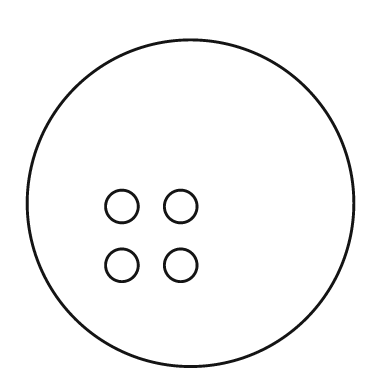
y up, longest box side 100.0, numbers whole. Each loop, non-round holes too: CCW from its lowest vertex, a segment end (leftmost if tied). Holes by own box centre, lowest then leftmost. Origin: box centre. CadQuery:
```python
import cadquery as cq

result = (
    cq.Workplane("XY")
    .moveTo(0.0, 0.0)
    .circle(50.0)
    .moveTo(-21.0, -19.0)
    .circle(5.0)
    .moveTo(-3.0, -19.0)
    .circle(5.0)
    .moveTo(-21.0, -1.0)
    .circle(5.0)
    .moveTo(-3.0, -1.0)
    .circle(5.0)
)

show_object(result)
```